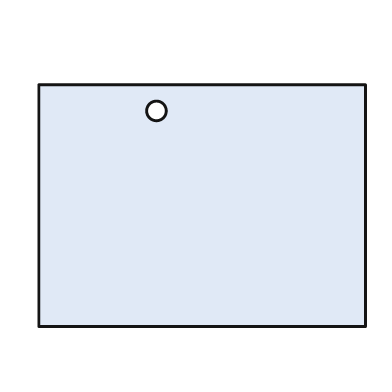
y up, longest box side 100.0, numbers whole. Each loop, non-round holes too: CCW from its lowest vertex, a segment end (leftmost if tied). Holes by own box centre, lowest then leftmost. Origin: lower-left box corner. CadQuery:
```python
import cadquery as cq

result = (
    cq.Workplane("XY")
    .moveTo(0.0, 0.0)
    .lineTo(100.0, 0.0)
    .lineTo(100.0, 74.0)
    .lineTo(0.0, 74.0)
    .close()
    .moveTo(36.0, 66.0)
    .circle(3.0)
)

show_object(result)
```